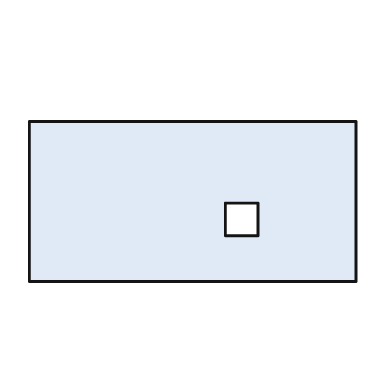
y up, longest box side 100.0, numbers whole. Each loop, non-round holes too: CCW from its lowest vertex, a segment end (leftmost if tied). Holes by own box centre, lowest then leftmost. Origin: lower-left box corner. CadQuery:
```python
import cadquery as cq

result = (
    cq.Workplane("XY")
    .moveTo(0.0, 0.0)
    .lineTo(100.0, 0.0)
    .lineTo(100.0, 49.0)
    .lineTo(0.0, 49.0)
    .close()
    .moveTo(60.0, 14.0)
    .lineTo(70.0, 14.0)
    .lineTo(70.0, 24.0)
    .lineTo(60.0, 24.0)
    .close()
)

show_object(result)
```